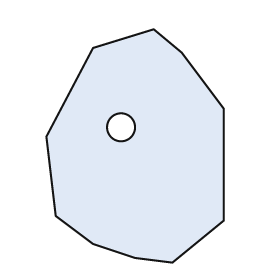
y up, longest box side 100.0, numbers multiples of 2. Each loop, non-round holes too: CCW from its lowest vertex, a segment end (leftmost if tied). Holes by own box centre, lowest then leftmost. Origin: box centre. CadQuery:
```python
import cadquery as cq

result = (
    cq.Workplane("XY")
    .moveTo(16.0, -50.0)
    .lineTo(38.0, -32.0)
    .lineTo(38.0, 16.0)
    .lineTo(20.0, 40.0)
    .lineTo(8.0, 50.0)
    .lineTo(-18.0, 42.0)
    .lineTo(-38.0, 4.0)
    .lineTo(-34.0, -30.0)
    .lineTo(-18.0, -42.0)
    .lineTo(0.0, -48.0)
    .close()
    .moveTo(-6.0, 8.0)
    .circle(6.0)
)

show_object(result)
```